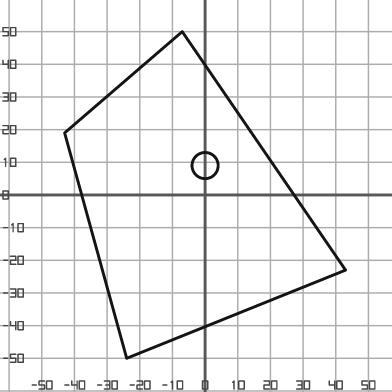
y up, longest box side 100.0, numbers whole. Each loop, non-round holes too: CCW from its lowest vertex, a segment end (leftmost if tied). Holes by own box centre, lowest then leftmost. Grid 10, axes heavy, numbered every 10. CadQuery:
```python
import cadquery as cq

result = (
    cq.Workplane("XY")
    .moveTo(-24.0, -50.0)
    .lineTo(43.0, -23.0)
    .lineTo(-7.0, 50.0)
    .lineTo(-43.0, 19.0)
    .close()
    .moveTo(0.0, 9.0)
    .circle(4.0)
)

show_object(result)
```